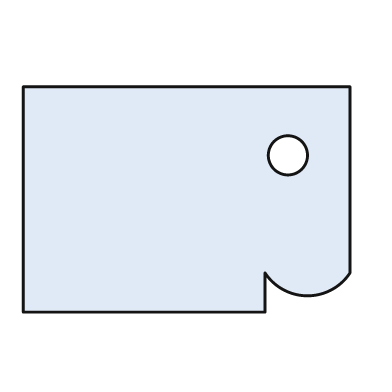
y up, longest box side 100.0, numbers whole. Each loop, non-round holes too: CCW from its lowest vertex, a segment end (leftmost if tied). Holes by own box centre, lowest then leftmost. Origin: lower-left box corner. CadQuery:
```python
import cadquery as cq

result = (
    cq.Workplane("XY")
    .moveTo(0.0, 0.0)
    .lineTo(74.0, 0.0)
    .lineTo(74.0, 12.0)
    .threePointArc((87.0, 5.0), (100.0, 12.0))
    .lineTo(100.0, 69.0)
    .lineTo(0.0, 69.0)
    .close()
    .moveTo(81.0, 48.0)
    .circle(6.0)
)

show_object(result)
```